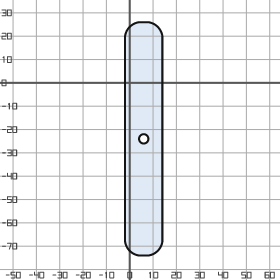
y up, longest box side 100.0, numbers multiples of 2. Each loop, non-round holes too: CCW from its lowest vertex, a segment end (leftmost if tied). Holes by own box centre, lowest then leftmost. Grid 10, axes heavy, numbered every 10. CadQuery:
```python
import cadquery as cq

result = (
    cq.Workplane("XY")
    .moveTo(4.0, -74.0)
    .lineTo(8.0, -74.0)
    .threePointArc((12.0, -72.0), (14.0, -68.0))
    .lineTo(14.0, 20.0)
    .threePointArc((12.0, 24.0), (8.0, 26.0))
    .lineTo(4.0, 26.0)
    .threePointArc((0.0, 24.0), (-2.0, 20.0))
    .lineTo(-2.0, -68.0)
    .threePointArc((0.0, -72.0), (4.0, -74.0))
    .close()
    .moveTo(6.0, -24.0)
    .circle(2.0)
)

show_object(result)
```